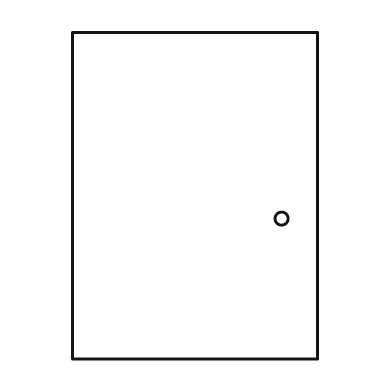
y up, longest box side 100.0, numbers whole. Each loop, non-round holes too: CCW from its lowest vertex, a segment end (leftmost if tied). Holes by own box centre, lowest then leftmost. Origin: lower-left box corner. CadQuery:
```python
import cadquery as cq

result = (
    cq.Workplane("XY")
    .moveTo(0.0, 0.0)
    .lineTo(75.0, 0.0)
    .lineTo(75.0, 100.0)
    .lineTo(0.0, 100.0)
    .close()
    .moveTo(64.0, 43.0)
    .circle(2.0)
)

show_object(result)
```